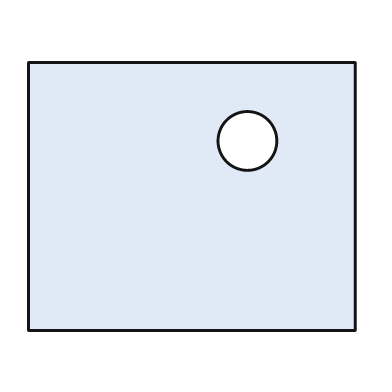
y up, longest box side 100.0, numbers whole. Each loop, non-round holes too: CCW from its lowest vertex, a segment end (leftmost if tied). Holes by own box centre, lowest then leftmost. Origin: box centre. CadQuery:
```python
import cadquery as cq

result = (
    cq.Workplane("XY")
    .moveTo(-50.0, -41.0)
    .lineTo(50.0, -41.0)
    .lineTo(50.0, 41.0)
    .lineTo(-50.0, 41.0)
    .close()
    .moveTo(17.0, 17.0)
    .circle(9.0)
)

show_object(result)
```